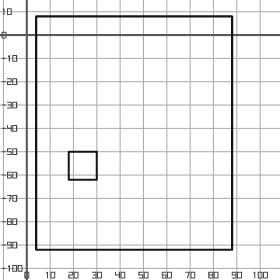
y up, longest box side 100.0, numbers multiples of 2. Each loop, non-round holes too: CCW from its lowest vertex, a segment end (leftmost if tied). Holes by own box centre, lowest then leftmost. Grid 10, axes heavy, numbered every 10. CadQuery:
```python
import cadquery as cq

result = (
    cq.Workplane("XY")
    .moveTo(4.0, -92.0)
    .lineTo(88.0, -92.0)
    .lineTo(88.0, 8.0)
    .lineTo(4.0, 8.0)
    .close()
    .moveTo(18.0, -62.0)
    .lineTo(30.0, -62.0)
    .lineTo(30.0, -50.0)
    .lineTo(18.0, -50.0)
    .close()
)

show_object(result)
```